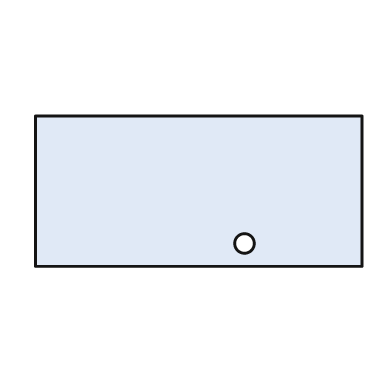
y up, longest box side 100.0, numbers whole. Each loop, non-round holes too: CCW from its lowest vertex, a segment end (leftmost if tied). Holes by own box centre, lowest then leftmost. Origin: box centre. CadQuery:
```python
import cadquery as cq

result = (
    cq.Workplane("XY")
    .moveTo(-50.0, -23.0)
    .lineTo(50.0, -23.0)
    .lineTo(50.0, 23.0)
    .lineTo(-50.0, 23.0)
    .close()
    .moveTo(14.0, -16.0)
    .circle(3.0)
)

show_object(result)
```